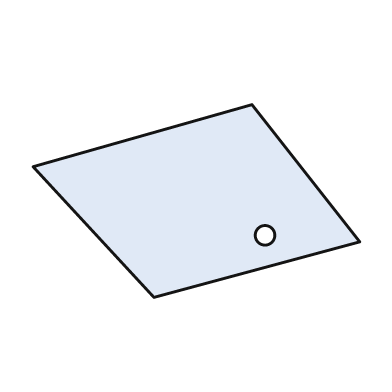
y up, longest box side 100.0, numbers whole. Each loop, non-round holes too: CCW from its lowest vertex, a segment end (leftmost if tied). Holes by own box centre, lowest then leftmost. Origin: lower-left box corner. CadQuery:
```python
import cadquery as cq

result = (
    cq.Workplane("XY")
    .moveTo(37.0, 0.0)
    .lineTo(100.0, 17.0)
    .lineTo(67.0, 59.0)
    .lineTo(0.0, 40.0)
    .close()
    .moveTo(71.0, 19.0)
    .circle(3.0)
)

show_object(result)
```